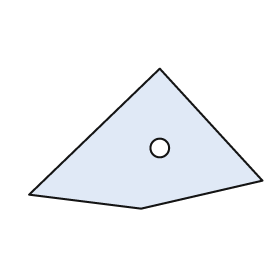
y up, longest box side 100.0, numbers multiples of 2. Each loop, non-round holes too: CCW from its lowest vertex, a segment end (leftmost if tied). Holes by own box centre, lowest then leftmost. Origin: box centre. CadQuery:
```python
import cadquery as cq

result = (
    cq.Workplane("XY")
    .moveTo(-2.0, -30.0)
    .lineTo(50.0, -18.0)
    .lineTo(6.0, 30.0)
    .lineTo(-50.0, -24.0)
    .close()
    .moveTo(6.0, -4.0)
    .circle(4.0)
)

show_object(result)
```